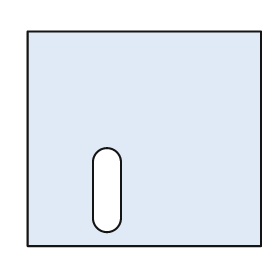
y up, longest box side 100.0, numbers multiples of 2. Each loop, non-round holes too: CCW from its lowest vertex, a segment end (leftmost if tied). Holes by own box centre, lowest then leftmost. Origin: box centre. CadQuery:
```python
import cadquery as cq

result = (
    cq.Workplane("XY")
    .moveTo(-50.0, -46.0)
    .lineTo(50.0, -46.0)
    .lineTo(50.0, 46.0)
    .lineTo(-50.0, 46.0)
    .close()
    .moveTo(-22.0, -34.0)
    .threePointArc((-16.0, -40.0), (-10.0, -34.0))
    .lineTo(-10.0, -10.0)
    .threePointArc((-16.0, -4.0), (-22.0, -10.0))
    .close()
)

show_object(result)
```